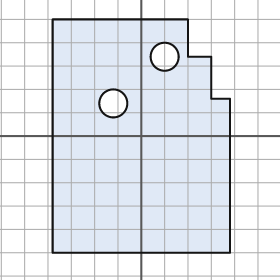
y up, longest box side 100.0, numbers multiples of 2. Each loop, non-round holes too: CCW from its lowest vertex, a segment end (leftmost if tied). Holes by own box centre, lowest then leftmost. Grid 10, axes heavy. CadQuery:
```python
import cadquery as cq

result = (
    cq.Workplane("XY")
    .moveTo(-38.0, -50.0)
    .lineTo(38.0, -50.0)
    .lineTo(38.0, 16.0)
    .lineTo(30.0, 16.0)
    .lineTo(30.0, 34.0)
    .lineTo(20.0, 34.0)
    .lineTo(20.0, 50.0)
    .lineTo(-38.0, 50.0)
    .close()
    .moveTo(-12.0, 14.0)
    .circle(6.0)
    .moveTo(10.0, 34.0)
    .circle(6.0)
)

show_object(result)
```